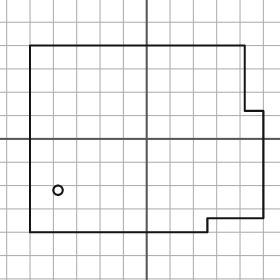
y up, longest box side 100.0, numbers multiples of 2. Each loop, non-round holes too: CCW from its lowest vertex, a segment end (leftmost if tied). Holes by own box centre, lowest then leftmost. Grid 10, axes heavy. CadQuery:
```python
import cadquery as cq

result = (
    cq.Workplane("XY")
    .moveTo(-50.0, -40.0)
    .lineTo(26.0, -40.0)
    .lineTo(26.0, -34.0)
    .lineTo(50.0, -34.0)
    .lineTo(50.0, 12.0)
    .lineTo(42.0, 12.0)
    .lineTo(42.0, 40.0)
    .lineTo(-50.0, 40.0)
    .close()
    .moveTo(-38.0, -22.0)
    .circle(2.0)
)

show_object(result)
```